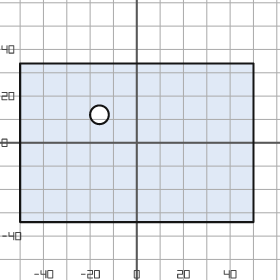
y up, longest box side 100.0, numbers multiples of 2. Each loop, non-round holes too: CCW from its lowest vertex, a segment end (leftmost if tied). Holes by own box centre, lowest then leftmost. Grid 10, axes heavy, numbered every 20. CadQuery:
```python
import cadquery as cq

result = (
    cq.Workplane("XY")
    .moveTo(-50.0, -34.0)
    .lineTo(50.0, -34.0)
    .lineTo(50.0, 34.0)
    .lineTo(-50.0, 34.0)
    .close()
    .moveTo(-16.0, 12.0)
    .circle(4.0)
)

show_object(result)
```